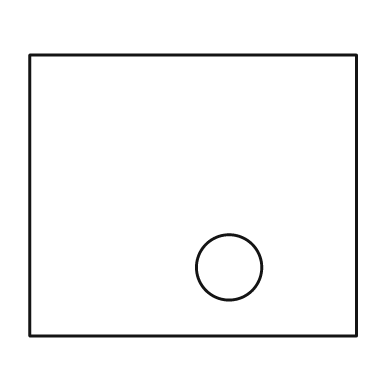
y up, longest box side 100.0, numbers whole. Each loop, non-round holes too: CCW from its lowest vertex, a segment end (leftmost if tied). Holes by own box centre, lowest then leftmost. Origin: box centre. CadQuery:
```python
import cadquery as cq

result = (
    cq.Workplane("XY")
    .moveTo(-50.0, -43.0)
    .lineTo(50.0, -43.0)
    .lineTo(50.0, 43.0)
    .lineTo(-50.0, 43.0)
    .close()
    .moveTo(11.0, -22.0)
    .circle(10.0)
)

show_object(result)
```